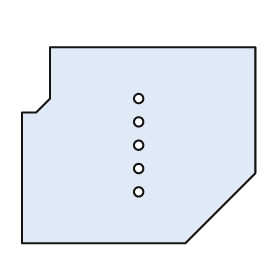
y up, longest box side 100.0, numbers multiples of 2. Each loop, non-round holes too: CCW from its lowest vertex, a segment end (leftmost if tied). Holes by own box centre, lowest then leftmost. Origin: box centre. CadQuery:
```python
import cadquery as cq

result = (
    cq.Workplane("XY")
    .moveTo(-50.0, -42.0)
    .lineTo(20.0, -42.0)
    .lineTo(50.0, -12.0)
    .lineTo(50.0, 42.0)
    .lineTo(-38.0, 42.0)
    .lineTo(-38.0, 20.0)
    .lineTo(-44.0, 14.0)
    .lineTo(-50.0, 14.0)
    .close()
    .moveTo(0.0, -20.0)
    .circle(2.0)
    .moveTo(0.0, -10.0)
    .circle(2.0)
    .moveTo(0.0, 0.0)
    .circle(2.0)
    .moveTo(0.0, 10.0)
    .circle(2.0)
    .moveTo(0.0, 20.0)
    .circle(2.0)
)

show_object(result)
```